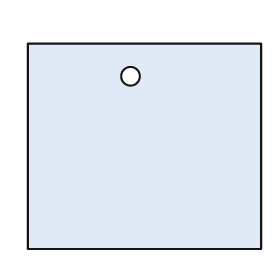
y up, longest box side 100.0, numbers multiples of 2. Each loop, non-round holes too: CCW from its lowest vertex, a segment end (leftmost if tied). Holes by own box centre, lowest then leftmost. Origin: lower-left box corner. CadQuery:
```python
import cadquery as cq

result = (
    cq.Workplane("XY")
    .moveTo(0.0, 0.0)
    .lineTo(100.0, 0.0)
    .lineTo(100.0, 88.0)
    .lineTo(0.0, 88.0)
    .close()
    .moveTo(44.0, 74.0)
    .circle(4.0)
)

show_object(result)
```